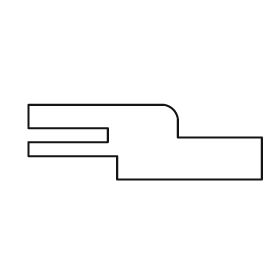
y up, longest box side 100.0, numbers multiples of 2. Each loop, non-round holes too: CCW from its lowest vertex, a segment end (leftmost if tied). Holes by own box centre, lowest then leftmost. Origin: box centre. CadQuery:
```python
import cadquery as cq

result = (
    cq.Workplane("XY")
    .moveTo(-12.0, -16.0)
    .lineTo(50.0, -16.0)
    .lineTo(50.0, 2.0)
    .lineTo(14.0, 2.0)
    .lineTo(14.0, 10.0)
    .threePointArc((12.0, 14.0), (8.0, 16.0))
    .lineTo(-50.0, 16.0)
    .lineTo(-50.0, 6.0)
    .lineTo(-16.0, 6.0)
    .lineTo(-16.0, 0.0)
    .lineTo(-50.0, 0.0)
    .lineTo(-50.0, -6.0)
    .lineTo(-12.0, -6.0)
    .close()
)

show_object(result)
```